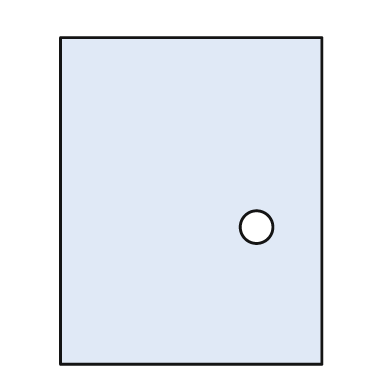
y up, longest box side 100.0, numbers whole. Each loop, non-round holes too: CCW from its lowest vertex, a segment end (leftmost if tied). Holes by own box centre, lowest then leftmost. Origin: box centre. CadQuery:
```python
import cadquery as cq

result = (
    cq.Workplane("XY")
    .moveTo(-40.0, -50.0)
    .lineTo(40.0, -50.0)
    .lineTo(40.0, 50.0)
    .lineTo(-40.0, 50.0)
    .close()
    .moveTo(20.0, -8.0)
    .circle(5.0)
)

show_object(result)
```